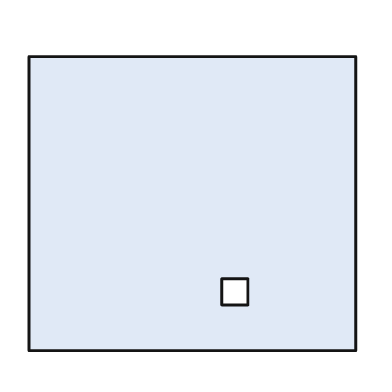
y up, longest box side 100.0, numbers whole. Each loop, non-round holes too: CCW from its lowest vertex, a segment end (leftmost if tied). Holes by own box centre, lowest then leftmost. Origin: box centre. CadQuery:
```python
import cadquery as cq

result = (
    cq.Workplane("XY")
    .moveTo(-50.0, -45.0)
    .lineTo(50.0, -45.0)
    .lineTo(50.0, 45.0)
    .lineTo(-50.0, 45.0)
    .close()
    .moveTo(9.0, -31.0)
    .lineTo(17.0, -31.0)
    .lineTo(17.0, -23.0)
    .lineTo(9.0, -23.0)
    .close()
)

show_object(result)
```